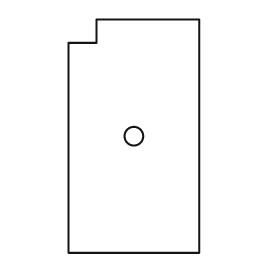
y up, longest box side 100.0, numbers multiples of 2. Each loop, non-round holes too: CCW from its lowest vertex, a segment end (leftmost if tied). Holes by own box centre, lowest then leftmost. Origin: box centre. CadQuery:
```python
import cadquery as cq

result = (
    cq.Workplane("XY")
    .moveTo(-28.0, -50.0)
    .lineTo(28.0, -50.0)
    .lineTo(28.0, 50.0)
    .lineTo(-16.0, 50.0)
    .lineTo(-16.0, 40.0)
    .lineTo(-28.0, 40.0)
    .close()
    .moveTo(0.0, 0.0)
    .circle(4.0)
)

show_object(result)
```